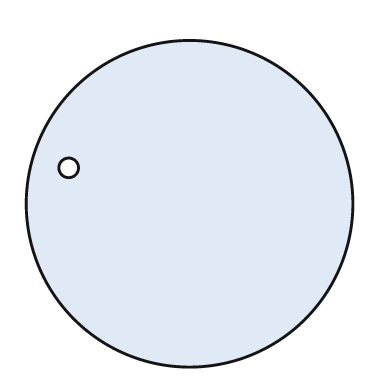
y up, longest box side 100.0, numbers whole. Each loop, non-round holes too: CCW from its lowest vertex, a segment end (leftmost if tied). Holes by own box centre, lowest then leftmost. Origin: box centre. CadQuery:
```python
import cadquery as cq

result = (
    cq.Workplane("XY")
    .moveTo(0.0, 0.0)
    .circle(50.0)
    .moveTo(-37.0, 11.0)
    .circle(3.0)
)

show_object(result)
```